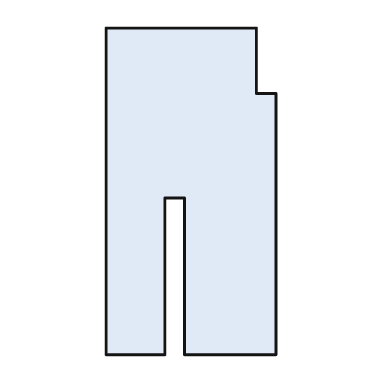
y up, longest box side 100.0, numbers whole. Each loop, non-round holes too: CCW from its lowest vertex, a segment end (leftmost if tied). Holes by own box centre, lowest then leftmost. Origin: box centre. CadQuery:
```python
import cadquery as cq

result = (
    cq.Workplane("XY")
    .moveTo(-26.0, -50.0)
    .lineTo(-8.0, -50.0)
    .lineTo(-8.0, -2.0)
    .lineTo(-2.0, -2.0)
    .lineTo(-2.0, -50.0)
    .lineTo(26.0, -50.0)
    .lineTo(26.0, 30.0)
    .lineTo(20.0, 30.0)
    .lineTo(20.0, 50.0)
    .lineTo(-26.0, 50.0)
    .close()
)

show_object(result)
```